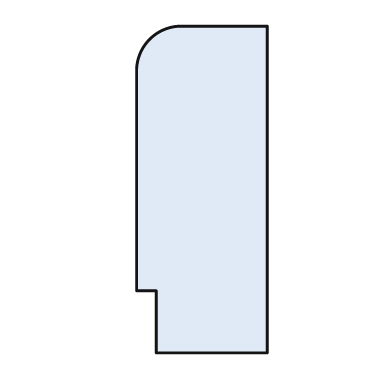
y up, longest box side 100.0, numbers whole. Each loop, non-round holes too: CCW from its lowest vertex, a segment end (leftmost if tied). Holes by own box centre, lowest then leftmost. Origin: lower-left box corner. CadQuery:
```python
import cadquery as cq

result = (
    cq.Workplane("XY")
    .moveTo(6.0, 0.0)
    .lineTo(40.0, 0.0)
    .lineTo(40.0, 100.0)
    .lineTo(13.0, 100.0)
    .threePointArc((4.0, 96.0), (0.0, 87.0))
    .lineTo(0.0, 19.0)
    .lineTo(6.0, 19.0)
    .close()
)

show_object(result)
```